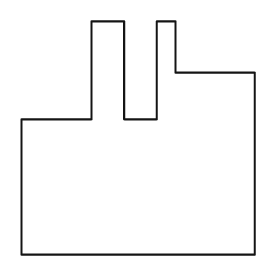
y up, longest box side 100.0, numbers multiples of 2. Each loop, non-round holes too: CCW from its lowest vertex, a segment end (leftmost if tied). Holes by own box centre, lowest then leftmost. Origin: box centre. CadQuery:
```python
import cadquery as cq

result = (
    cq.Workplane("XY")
    .moveTo(-50.0, -50.0)
    .lineTo(50.0, -50.0)
    .lineTo(50.0, 28.0)
    .lineTo(16.0, 28.0)
    .lineTo(16.0, 50.0)
    .lineTo(8.0, 50.0)
    .lineTo(8.0, 8.0)
    .lineTo(-6.0, 8.0)
    .lineTo(-6.0, 50.0)
    .lineTo(-20.0, 50.0)
    .lineTo(-20.0, 8.0)
    .lineTo(-50.0, 8.0)
    .close()
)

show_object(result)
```